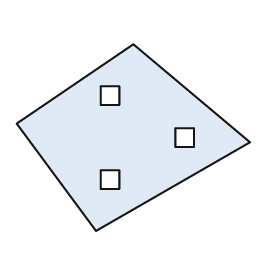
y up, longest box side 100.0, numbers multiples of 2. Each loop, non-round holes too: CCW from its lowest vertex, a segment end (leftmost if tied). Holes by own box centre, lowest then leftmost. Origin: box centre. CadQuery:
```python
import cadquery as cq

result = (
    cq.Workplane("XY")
    .moveTo(-16.0, -40.0)
    .lineTo(50.0, -2.0)
    .lineTo(0.0, 40.0)
    .lineTo(-50.0, 6.0)
    .close()
    .moveTo(-14.0, -22.0)
    .lineTo(-6.0, -22.0)
    .lineTo(-6.0, -14.0)
    .lineTo(-14.0, -14.0)
    .close()
    .moveTo(18.0, -4.0)
    .lineTo(26.0, -4.0)
    .lineTo(26.0, 4.0)
    .lineTo(18.0, 4.0)
    .close()
    .moveTo(-14.0, 14.0)
    .lineTo(-6.0, 14.0)
    .lineTo(-6.0, 22.0)
    .lineTo(-14.0, 22.0)
    .close()
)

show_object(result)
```